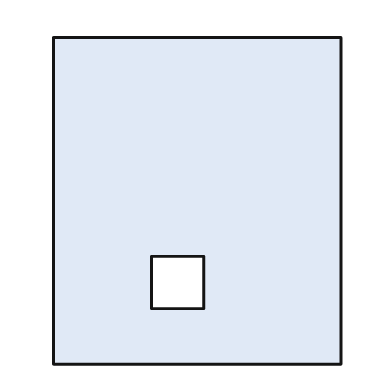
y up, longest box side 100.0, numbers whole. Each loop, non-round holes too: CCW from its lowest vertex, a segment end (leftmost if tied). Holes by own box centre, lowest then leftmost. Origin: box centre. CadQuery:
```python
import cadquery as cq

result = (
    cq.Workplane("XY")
    .moveTo(-44.0, -50.0)
    .lineTo(44.0, -50.0)
    .lineTo(44.0, 50.0)
    .lineTo(-44.0, 50.0)
    .close()
    .moveTo(-14.0, -33.0)
    .lineTo(2.0, -33.0)
    .lineTo(2.0, -17.0)
    .lineTo(-14.0, -17.0)
    .close()
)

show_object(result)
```